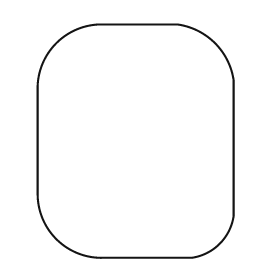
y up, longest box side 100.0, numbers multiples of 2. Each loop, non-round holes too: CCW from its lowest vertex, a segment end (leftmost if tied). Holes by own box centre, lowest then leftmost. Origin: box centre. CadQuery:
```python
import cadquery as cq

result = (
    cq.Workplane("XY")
    .moveTo(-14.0, -50.0)
    .lineTo(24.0, -50.0)
    .threePointArc((36.0, -44.0), (42.0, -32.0))
    .lineTo(42.0, 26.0)
    .threePointArc((34.0, 42.0), (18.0, 50.0))
    .lineTo(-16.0, 50.0)
    .threePointArc((-34.0, 42.0), (-42.0, 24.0))
    .lineTo(-42.0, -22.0)
    .threePointArc((-34.0, -42.0), (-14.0, -50.0))
    .close()
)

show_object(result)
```